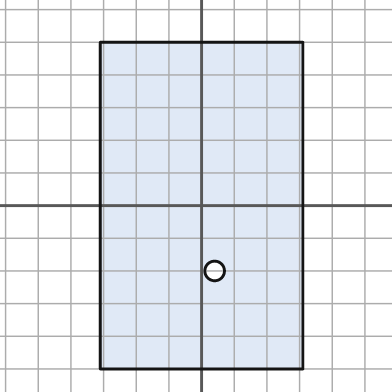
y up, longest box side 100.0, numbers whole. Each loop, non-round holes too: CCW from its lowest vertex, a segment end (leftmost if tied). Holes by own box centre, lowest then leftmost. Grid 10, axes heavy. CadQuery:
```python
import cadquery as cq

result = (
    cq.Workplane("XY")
    .moveTo(-31.0, -50.0)
    .lineTo(31.0, -50.0)
    .lineTo(31.0, 50.0)
    .lineTo(-31.0, 50.0)
    .close()
    .moveTo(4.0, -20.0)
    .circle(3.0)
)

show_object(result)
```